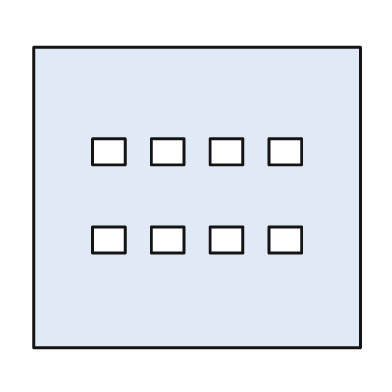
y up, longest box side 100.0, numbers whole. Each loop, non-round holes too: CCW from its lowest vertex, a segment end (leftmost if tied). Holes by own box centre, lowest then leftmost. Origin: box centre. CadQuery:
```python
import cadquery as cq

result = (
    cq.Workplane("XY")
    .moveTo(-50.0, -46.0)
    .lineTo(50.0, -46.0)
    .lineTo(50.0, 46.0)
    .lineTo(-50.0, 46.0)
    .close()
    .moveTo(-32.0, -17.0)
    .lineTo(-22.0, -17.0)
    .lineTo(-22.0, -9.0)
    .lineTo(-32.0, -9.0)
    .close()
    .moveTo(-14.0, -17.0)
    .lineTo(-4.0, -17.0)
    .lineTo(-4.0, -9.0)
    .lineTo(-14.0, -9.0)
    .close()
    .moveTo(4.0, -17.0)
    .lineTo(14.0, -17.0)
    .lineTo(14.0, -9.0)
    .lineTo(4.0, -9.0)
    .close()
    .moveTo(22.0, -17.0)
    .lineTo(32.0, -17.0)
    .lineTo(32.0, -9.0)
    .lineTo(22.0, -9.0)
    .close()
    .moveTo(-32.0, 10.0)
    .lineTo(-22.0, 10.0)
    .lineTo(-22.0, 18.0)
    .lineTo(-32.0, 18.0)
    .close()
    .moveTo(-14.0, 10.0)
    .lineTo(-4.0, 10.0)
    .lineTo(-4.0, 18.0)
    .lineTo(-14.0, 18.0)
    .close()
    .moveTo(4.0, 10.0)
    .lineTo(14.0, 10.0)
    .lineTo(14.0, 18.0)
    .lineTo(4.0, 18.0)
    .close()
    .moveTo(22.0, 10.0)
    .lineTo(32.0, 10.0)
    .lineTo(32.0, 18.0)
    .lineTo(22.0, 18.0)
    .close()
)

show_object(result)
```